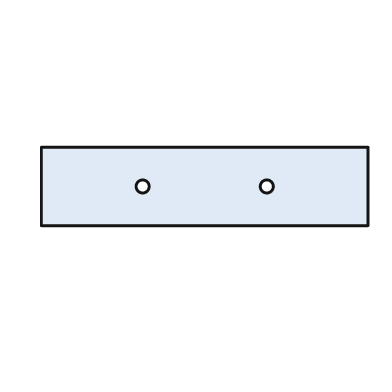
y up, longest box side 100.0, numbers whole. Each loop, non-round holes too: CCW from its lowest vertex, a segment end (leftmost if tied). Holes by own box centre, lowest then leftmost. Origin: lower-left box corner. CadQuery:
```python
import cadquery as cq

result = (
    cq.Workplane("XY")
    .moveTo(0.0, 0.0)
    .lineTo(100.0, 0.0)
    .lineTo(100.0, 24.0)
    .lineTo(0.0, 24.0)
    .close()
    .moveTo(31.0, 12.0)
    .circle(2.0)
    .moveTo(69.0, 12.0)
    .circle(2.0)
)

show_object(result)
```